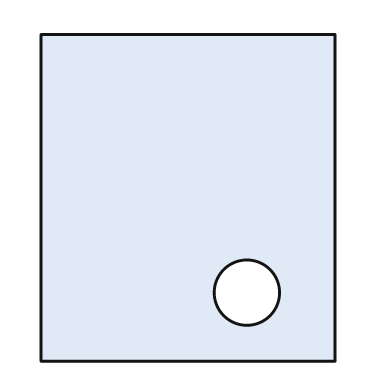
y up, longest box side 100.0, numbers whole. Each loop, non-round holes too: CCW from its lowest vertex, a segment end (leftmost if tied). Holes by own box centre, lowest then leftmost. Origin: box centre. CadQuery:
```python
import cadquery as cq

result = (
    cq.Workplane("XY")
    .moveTo(-45.0, -50.0)
    .lineTo(45.0, -50.0)
    .lineTo(45.0, 50.0)
    .lineTo(-45.0, 50.0)
    .close()
    .moveTo(18.0, -29.0)
    .circle(10.0)
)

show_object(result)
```